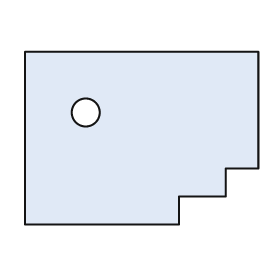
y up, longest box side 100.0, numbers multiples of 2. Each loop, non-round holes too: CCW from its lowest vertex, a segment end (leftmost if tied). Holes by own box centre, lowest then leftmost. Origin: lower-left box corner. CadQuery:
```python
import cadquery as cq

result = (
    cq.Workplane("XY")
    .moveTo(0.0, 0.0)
    .lineTo(66.0, 0.0)
    .lineTo(66.0, 12.0)
    .lineTo(86.0, 12.0)
    .lineTo(86.0, 24.0)
    .lineTo(100.0, 24.0)
    .lineTo(100.0, 74.0)
    .lineTo(0.0, 74.0)
    .close()
    .moveTo(26.0, 48.0)
    .circle(6.0)
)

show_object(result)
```